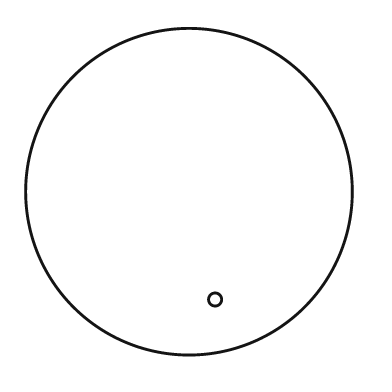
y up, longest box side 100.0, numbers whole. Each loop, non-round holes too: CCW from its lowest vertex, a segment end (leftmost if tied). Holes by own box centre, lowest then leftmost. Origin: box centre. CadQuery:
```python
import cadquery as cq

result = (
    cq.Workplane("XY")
    .moveTo(0.0, 0.0)
    .circle(50.0)
    .moveTo(8.0, -33.0)
    .circle(2.0)
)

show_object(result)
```